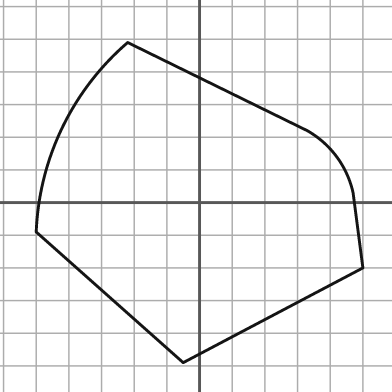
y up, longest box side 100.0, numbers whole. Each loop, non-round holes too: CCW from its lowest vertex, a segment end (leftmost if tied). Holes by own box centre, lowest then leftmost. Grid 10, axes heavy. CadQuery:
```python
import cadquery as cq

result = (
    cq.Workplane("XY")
    .moveTo(-5.0, -49.0)
    .lineTo(50.0, -20.0)
    .lineTo(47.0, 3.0)
    .threePointArc((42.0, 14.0), (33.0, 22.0))
    .lineTo(-22.0, 49.0)
    .threePointArc((-42.0, 23.0), (-50.0, -9.0))
    .close()
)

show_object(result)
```